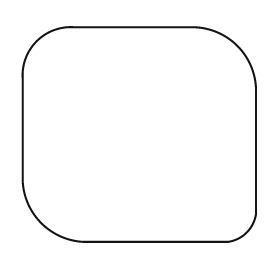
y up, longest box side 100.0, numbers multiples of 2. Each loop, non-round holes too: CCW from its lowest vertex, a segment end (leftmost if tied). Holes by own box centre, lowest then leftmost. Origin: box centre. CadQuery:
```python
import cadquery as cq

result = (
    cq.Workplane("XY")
    .moveTo(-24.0, -46.0)
    .lineTo(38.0, -46.0)
    .threePointArc((46.0, -42.0), (50.0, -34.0))
    .lineTo(50.0, 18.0)
    .threePointArc((42.0, 38.0), (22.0, 46.0))
    .lineTo(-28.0, 46.0)
    .threePointArc((-44.0, 40.0), (-50.0, 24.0))
    .lineTo(-50.0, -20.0)
    .threePointArc((-42.0, -38.0), (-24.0, -46.0))
    .close()
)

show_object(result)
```